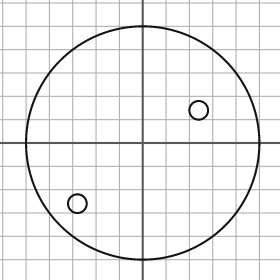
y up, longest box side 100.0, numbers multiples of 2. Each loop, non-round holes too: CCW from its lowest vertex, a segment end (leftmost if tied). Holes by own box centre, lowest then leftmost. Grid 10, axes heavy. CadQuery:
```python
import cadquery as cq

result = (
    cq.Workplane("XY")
    .moveTo(0.0, 0.0)
    .circle(50.0)
    .moveTo(-28.0, -26.0)
    .circle(4.0)
    .moveTo(24.0, 14.0)
    .circle(4.0)
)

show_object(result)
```